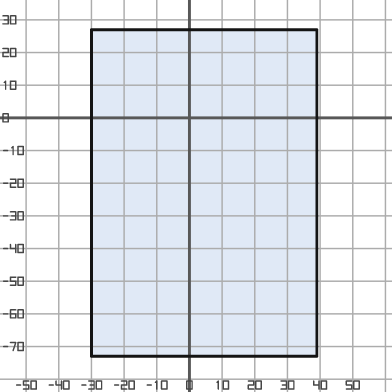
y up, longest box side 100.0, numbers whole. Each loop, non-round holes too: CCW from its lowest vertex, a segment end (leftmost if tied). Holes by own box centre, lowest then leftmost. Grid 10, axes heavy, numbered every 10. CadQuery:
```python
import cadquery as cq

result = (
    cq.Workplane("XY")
    .moveTo(-30.0, -73.0)
    .lineTo(39.0, -73.0)
    .lineTo(39.0, 27.0)
    .lineTo(-30.0, 27.0)
    .close()
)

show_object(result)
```